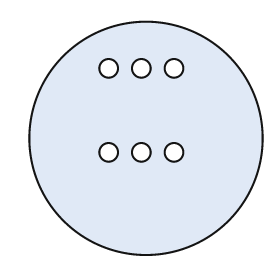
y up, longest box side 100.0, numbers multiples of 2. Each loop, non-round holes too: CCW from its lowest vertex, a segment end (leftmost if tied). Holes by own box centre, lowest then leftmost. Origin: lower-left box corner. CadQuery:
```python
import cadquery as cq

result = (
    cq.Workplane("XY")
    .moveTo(50.0, 50.0)
    .circle(50.0)
    .moveTo(34.0, 44.0)
    .circle(4.0)
    .moveTo(48.0, 44.0)
    .circle(4.0)
    .moveTo(62.0, 44.0)
    .circle(4.0)
    .moveTo(34.0, 80.0)
    .circle(4.0)
    .moveTo(48.0, 80.0)
    .circle(4.0)
    .moveTo(62.0, 80.0)
    .circle(4.0)
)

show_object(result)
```